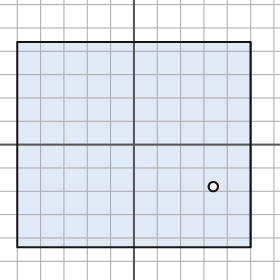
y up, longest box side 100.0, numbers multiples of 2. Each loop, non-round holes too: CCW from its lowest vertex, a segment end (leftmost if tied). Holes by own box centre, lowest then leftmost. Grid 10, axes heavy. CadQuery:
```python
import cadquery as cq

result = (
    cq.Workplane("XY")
    .moveTo(-50.0, -44.0)
    .lineTo(50.0, -44.0)
    .lineTo(50.0, 44.0)
    .lineTo(-50.0, 44.0)
    .close()
    .moveTo(34.0, -18.0)
    .circle(2.0)
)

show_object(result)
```